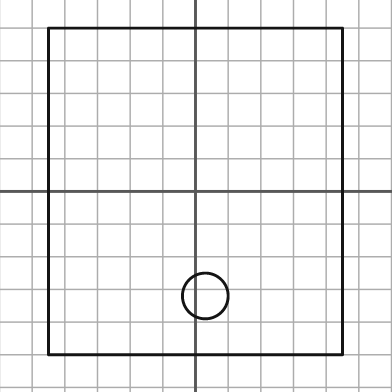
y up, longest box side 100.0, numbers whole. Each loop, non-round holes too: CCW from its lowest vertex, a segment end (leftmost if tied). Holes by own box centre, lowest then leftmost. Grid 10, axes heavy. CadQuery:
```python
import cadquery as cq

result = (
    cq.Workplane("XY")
    .moveTo(-45.0, -50.0)
    .lineTo(45.0, -50.0)
    .lineTo(45.0, 50.0)
    .lineTo(-45.0, 50.0)
    .close()
    .moveTo(3.0, -32.0)
    .circle(7.0)
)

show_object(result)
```